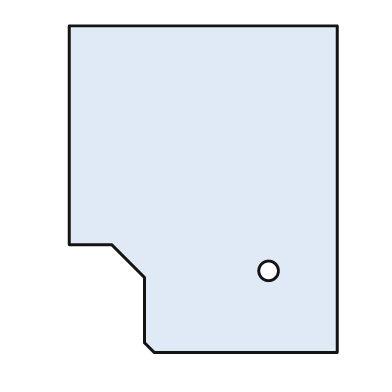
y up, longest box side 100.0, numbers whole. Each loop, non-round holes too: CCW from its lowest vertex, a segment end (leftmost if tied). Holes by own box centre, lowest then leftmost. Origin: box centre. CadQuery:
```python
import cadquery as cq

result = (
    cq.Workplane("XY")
    .moveTo(-15.0, -50.0)
    .lineTo(41.0, -50.0)
    .lineTo(41.0, 50.0)
    .lineTo(-41.0, 50.0)
    .lineTo(-41.0, -17.0)
    .lineTo(-28.0, -17.0)
    .lineTo(-18.0, -27.0)
    .lineTo(-18.0, -47.0)
    .close()
    .moveTo(20.0, -25.0)
    .circle(3.0)
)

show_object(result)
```